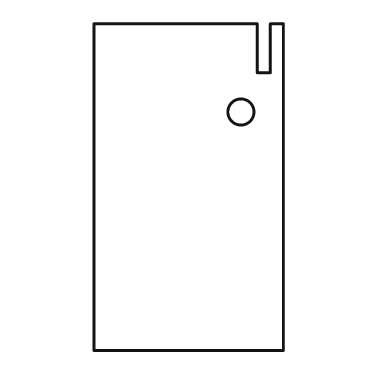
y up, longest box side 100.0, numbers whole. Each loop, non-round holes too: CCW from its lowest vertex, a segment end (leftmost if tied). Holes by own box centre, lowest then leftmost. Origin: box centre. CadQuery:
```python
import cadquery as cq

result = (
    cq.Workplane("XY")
    .moveTo(-29.0, -50.0)
    .lineTo(29.0, -50.0)
    .lineTo(29.0, 50.0)
    .lineTo(25.0, 50.0)
    .lineTo(25.0, 35.0)
    .lineTo(21.0, 35.0)
    .lineTo(21.0, 50.0)
    .lineTo(-29.0, 50.0)
    .close()
    .moveTo(16.0, 23.0)
    .circle(4.0)
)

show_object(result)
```